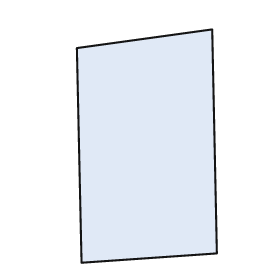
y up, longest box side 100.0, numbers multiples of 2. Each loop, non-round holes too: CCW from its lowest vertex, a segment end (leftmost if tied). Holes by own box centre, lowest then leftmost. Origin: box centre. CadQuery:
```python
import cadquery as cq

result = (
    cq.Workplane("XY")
    .moveTo(-28.0, -50.0)
    .lineTo(30.0, -46.0)
    .lineTo(28.0, 50.0)
    .lineTo(-30.0, 42.0)
    .close()
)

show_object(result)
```